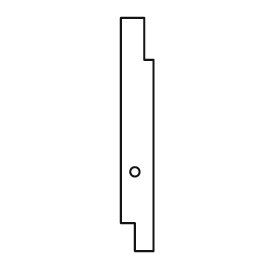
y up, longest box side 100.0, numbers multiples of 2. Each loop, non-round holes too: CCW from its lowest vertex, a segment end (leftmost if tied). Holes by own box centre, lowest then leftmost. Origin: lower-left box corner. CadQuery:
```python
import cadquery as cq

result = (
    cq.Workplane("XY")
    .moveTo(6.0, 0.0)
    .lineTo(14.0, 0.0)
    .lineTo(14.0, 82.0)
    .lineTo(10.0, 82.0)
    .lineTo(10.0, 100.0)
    .lineTo(0.0, 100.0)
    .lineTo(0.0, 12.0)
    .lineTo(6.0, 12.0)
    .close()
    .moveTo(6.0, 34.0)
    .circle(2.0)
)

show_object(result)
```